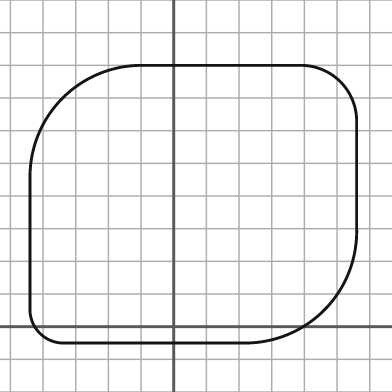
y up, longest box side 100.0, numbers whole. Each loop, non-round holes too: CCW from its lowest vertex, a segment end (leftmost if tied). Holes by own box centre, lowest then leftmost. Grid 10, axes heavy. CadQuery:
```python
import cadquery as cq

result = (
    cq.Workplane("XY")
    .moveTo(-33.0, -5.0)
    .lineTo(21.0, -5.0)
    .threePointArc((46.0, 5.0), (56.0, 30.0))
    .lineTo(56.0, 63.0)
    .threePointArc((51.0, 75.0), (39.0, 80.0))
    .lineTo(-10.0, 80.0)
    .threePointArc((-34.0, 70.0), (-44.0, 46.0))
    .lineTo(-44.0, 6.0)
    .threePointArc((-41.0, -2.0), (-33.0, -5.0))
    .close()
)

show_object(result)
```